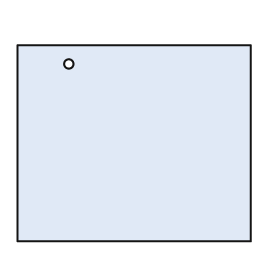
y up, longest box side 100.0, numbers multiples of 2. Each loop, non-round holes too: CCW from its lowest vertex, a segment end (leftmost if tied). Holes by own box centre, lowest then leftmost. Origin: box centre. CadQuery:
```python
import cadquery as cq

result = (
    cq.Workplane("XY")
    .moveTo(-50.0, -42.0)
    .lineTo(50.0, -42.0)
    .lineTo(50.0, 42.0)
    .lineTo(-50.0, 42.0)
    .close()
    .moveTo(-28.0, 34.0)
    .circle(2.0)
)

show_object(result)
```